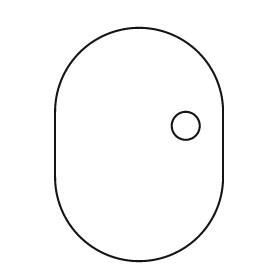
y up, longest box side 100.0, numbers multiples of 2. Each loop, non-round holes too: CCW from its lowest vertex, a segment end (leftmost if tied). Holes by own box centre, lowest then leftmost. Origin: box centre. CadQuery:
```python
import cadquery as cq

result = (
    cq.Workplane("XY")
    .moveTo(-36.0, -14.0)
    .threePointArc((0.0, -50.0), (36.0, -14.0))
    .lineTo(36.0, 14.0)
    .threePointArc((0.0, 50.0), (-36.0, 14.0))
    .close()
    .moveTo(20.0, 8.0)
    .circle(6.0)
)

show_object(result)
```